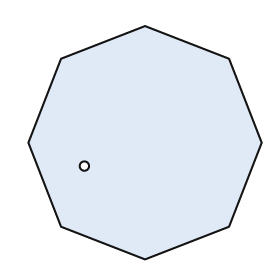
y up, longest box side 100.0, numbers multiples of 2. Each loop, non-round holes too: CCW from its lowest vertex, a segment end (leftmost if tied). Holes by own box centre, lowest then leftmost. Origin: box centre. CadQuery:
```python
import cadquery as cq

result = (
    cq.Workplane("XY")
    .moveTo(0.0, -50.0)
    .lineTo(36.0, -36.0)
    .lineTo(50.0, 0.0)
    .lineTo(36.0, 36.0)
    .lineTo(0.0, 50.0)
    .lineTo(-36.0, 36.0)
    .lineTo(-50.0, 0.0)
    .lineTo(-36.0, -36.0)
    .close()
    .moveTo(-26.0, -10.0)
    .circle(2.0)
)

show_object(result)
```